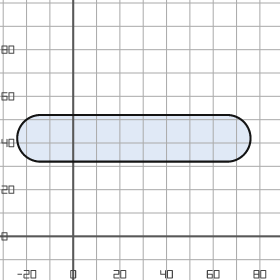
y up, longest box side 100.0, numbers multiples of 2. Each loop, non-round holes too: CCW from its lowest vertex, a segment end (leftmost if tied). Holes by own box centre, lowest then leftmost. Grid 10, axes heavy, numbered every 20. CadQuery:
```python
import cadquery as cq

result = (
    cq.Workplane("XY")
    .moveTo(-14.0, 32.0)
    .lineTo(66.0, 32.0)
    .threePointArc((76.0, 42.0), (66.0, 52.0))
    .lineTo(-14.0, 52.0)
    .threePointArc((-24.0, 42.0), (-14.0, 32.0))
    .close()
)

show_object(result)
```